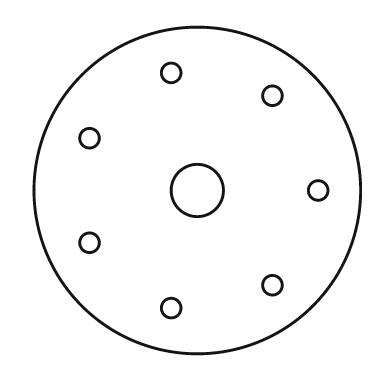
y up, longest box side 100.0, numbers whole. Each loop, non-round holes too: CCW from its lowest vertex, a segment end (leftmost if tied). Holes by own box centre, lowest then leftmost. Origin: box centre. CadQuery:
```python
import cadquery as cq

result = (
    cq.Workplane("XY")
    .moveTo(0.0, 0.0)
    .circle(50.0)
    .moveTo(-8.0, -36.0)
    .circle(3.0)
    .moveTo(23.0, -29.0)
    .circle(3.0)
    .moveTo(-33.0, -16.0)
    .circle(3.0)
    .moveTo(0.0, 0.0)
    .circle(8.0)
    .moveTo(37.0, 0.0)
    .circle(3.0)
    .moveTo(-33.0, 16.0)
    .circle(3.0)
    .moveTo(23.0, 29.0)
    .circle(3.0)
    .moveTo(-8.0, 36.0)
    .circle(3.0)
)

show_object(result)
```